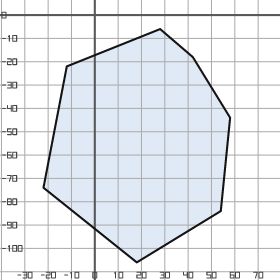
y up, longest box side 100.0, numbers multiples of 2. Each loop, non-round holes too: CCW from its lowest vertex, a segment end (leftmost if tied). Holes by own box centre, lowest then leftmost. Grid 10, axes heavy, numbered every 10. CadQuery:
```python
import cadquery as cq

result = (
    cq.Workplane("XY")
    .moveTo(18.0, -106.0)
    .lineTo(54.0, -84.0)
    .lineTo(58.0, -44.0)
    .lineTo(42.0, -18.0)
    .lineTo(28.0, -6.0)
    .lineTo(-12.0, -22.0)
    .lineTo(-22.0, -74.0)
    .close()
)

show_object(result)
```